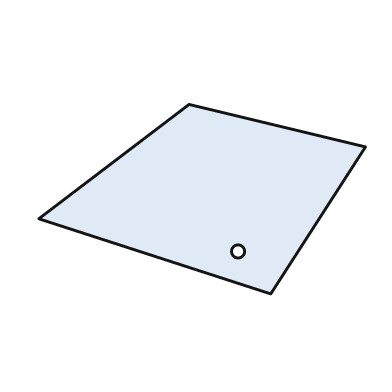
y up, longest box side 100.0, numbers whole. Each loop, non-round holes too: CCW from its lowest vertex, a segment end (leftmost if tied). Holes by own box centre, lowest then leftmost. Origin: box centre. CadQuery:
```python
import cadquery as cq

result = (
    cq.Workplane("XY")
    .moveTo(21.0, -29.0)
    .lineTo(50.0, 16.0)
    .lineTo(-4.0, 29.0)
    .lineTo(-50.0, -6.0)
    .close()
    .moveTo(11.0, -16.0)
    .circle(2.0)
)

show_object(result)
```